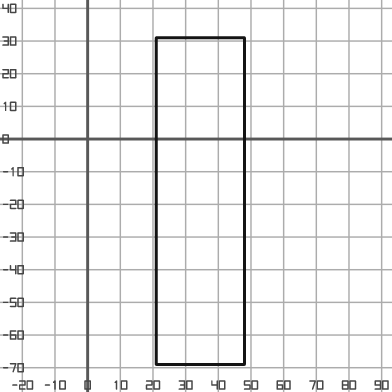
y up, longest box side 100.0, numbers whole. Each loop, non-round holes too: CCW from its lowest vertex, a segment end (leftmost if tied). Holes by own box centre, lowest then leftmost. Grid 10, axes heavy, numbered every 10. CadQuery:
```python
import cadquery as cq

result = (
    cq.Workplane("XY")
    .moveTo(21.0, -69.0)
    .lineTo(48.0, -69.0)
    .lineTo(48.0, 31.0)
    .lineTo(21.0, 31.0)
    .close()
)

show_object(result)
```